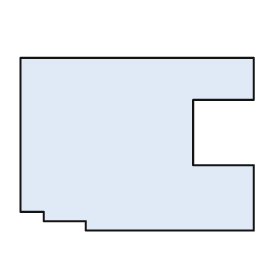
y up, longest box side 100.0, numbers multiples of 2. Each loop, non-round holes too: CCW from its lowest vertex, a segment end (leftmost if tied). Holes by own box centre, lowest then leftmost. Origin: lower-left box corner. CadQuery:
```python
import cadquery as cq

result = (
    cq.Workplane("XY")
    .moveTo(28.0, 0.0)
    .lineTo(100.0, 0.0)
    .lineTo(100.0, 28.0)
    .lineTo(74.0, 28.0)
    .lineTo(74.0, 56.0)
    .lineTo(100.0, 56.0)
    .lineTo(100.0, 74.0)
    .lineTo(0.0, 74.0)
    .lineTo(0.0, 8.0)
    .lineTo(10.0, 8.0)
    .lineTo(10.0, 4.0)
    .lineTo(28.0, 4.0)
    .close()
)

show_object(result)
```